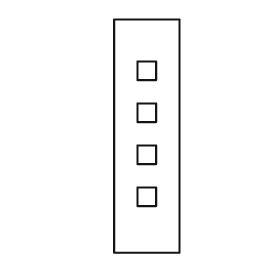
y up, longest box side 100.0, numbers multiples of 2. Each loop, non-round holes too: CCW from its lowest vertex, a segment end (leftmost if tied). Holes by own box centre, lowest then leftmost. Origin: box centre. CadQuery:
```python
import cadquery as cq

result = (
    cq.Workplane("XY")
    .moveTo(-14.0, -50.0)
    .lineTo(14.0, -50.0)
    .lineTo(14.0, 50.0)
    .lineTo(-14.0, 50.0)
    .close()
    .moveTo(-4.0, -30.0)
    .lineTo(4.0, -30.0)
    .lineTo(4.0, -22.0)
    .lineTo(-4.0, -22.0)
    .close()
    .moveTo(-4.0, -12.0)
    .lineTo(4.0, -12.0)
    .lineTo(4.0, -4.0)
    .lineTo(-4.0, -4.0)
    .close()
    .moveTo(-4.0, 6.0)
    .lineTo(4.0, 6.0)
    .lineTo(4.0, 14.0)
    .lineTo(-4.0, 14.0)
    .close()
    .moveTo(-4.0, 24.0)
    .lineTo(4.0, 24.0)
    .lineTo(4.0, 32.0)
    .lineTo(-4.0, 32.0)
    .close()
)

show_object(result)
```